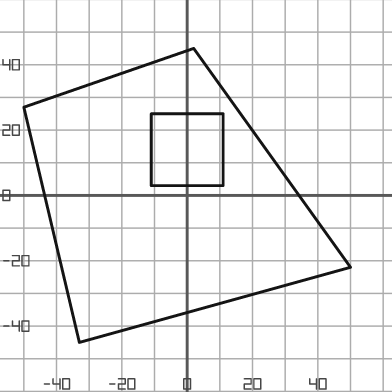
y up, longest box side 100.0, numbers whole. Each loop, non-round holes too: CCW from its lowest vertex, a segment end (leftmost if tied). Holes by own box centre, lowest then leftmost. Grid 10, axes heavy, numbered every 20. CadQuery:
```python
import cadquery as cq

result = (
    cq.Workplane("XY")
    .moveTo(-33.0, -45.0)
    .lineTo(50.0, -22.0)
    .lineTo(2.0, 45.0)
    .lineTo(-50.0, 27.0)
    .close()
    .moveTo(-11.0, 3.0)
    .lineTo(11.0, 3.0)
    .lineTo(11.0, 25.0)
    .lineTo(-11.0, 25.0)
    .close()
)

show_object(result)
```